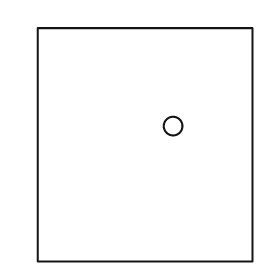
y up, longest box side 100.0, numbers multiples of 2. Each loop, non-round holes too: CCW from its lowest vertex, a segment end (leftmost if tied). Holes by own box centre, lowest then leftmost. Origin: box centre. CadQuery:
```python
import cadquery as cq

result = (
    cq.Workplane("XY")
    .moveTo(-46.0, -50.0)
    .lineTo(46.0, -50.0)
    .lineTo(46.0, 50.0)
    .lineTo(-46.0, 50.0)
    .close()
    .moveTo(12.0, 8.0)
    .circle(4.0)
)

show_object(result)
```